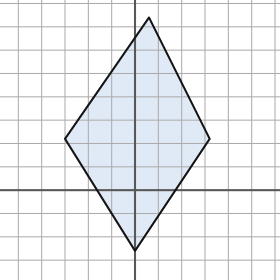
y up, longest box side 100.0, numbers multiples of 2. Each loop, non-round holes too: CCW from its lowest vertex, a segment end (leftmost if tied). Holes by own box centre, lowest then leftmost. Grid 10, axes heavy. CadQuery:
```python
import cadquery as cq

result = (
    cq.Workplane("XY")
    .moveTo(0.0, -26.0)
    .lineTo(32.0, 22.0)
    .lineTo(6.0, 74.0)
    .lineTo(-30.0, 22.0)
    .close()
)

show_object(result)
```